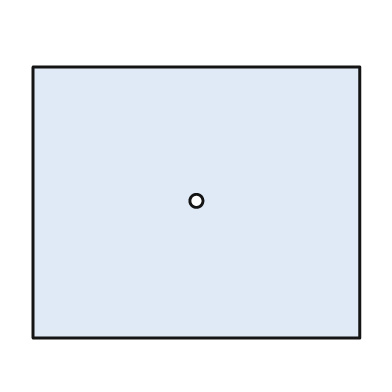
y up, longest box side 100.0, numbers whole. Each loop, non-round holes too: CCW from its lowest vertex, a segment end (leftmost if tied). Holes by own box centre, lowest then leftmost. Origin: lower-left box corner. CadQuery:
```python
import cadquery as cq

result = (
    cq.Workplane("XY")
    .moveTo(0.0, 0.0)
    .lineTo(100.0, 0.0)
    .lineTo(100.0, 83.0)
    .lineTo(0.0, 83.0)
    .close()
    .moveTo(50.0, 42.0)
    .circle(2.0)
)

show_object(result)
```